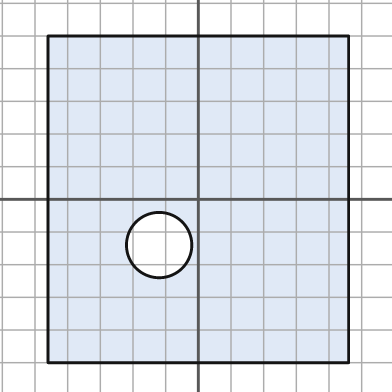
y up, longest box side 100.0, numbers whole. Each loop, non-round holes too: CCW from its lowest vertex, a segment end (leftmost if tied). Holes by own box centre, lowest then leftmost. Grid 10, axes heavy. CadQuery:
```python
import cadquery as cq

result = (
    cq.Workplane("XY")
    .moveTo(-46.0, -50.0)
    .lineTo(46.0, -50.0)
    .lineTo(46.0, 50.0)
    .lineTo(-46.0, 50.0)
    .close()
    .moveTo(-12.0, -14.0)
    .circle(10.0)
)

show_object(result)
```